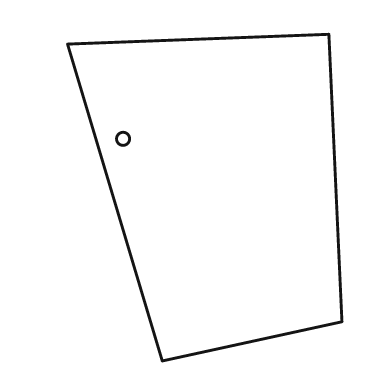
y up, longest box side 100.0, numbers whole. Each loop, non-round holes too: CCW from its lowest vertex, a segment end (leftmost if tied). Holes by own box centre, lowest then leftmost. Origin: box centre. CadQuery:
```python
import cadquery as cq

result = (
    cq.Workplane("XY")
    .moveTo(-13.0, -50.0)
    .lineTo(42.0, -38.0)
    .lineTo(38.0, 50.0)
    .lineTo(-42.0, 47.0)
    .close()
    .moveTo(-25.0, 18.0)
    .circle(2.0)
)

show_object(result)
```